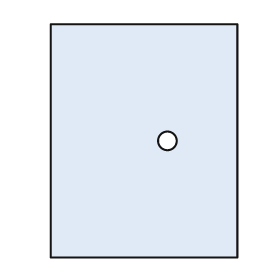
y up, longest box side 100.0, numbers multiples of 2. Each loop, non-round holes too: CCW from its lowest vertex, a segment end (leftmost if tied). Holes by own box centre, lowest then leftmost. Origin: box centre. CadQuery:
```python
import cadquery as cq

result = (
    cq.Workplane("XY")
    .moveTo(-40.0, -50.0)
    .lineTo(40.0, -50.0)
    .lineTo(40.0, 50.0)
    .lineTo(-40.0, 50.0)
    .close()
    .moveTo(10.0, 0.0)
    .circle(4.0)
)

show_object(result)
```